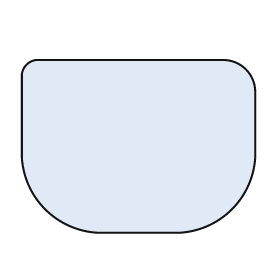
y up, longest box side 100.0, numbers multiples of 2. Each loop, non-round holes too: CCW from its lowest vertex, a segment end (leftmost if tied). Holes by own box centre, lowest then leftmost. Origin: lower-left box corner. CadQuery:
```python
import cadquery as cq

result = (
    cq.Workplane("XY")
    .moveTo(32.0, 0.0)
    .lineTo(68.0, 0.0)
    .threePointArc((90.0, 10.0), (100.0, 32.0))
    .lineTo(100.0, 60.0)
    .threePointArc((96.0, 70.0), (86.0, 74.0))
    .lineTo(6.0, 74.0)
    .threePointArc((2.0, 72.0), (0.0, 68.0))
    .lineTo(0.0, 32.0)
    .threePointArc((10.0, 10.0), (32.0, 0.0))
    .close()
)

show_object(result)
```